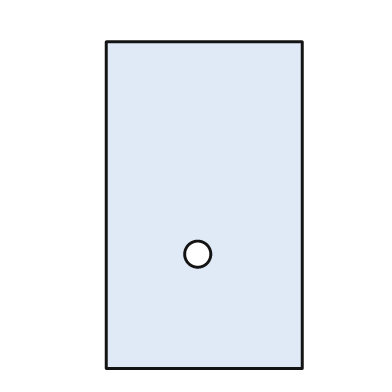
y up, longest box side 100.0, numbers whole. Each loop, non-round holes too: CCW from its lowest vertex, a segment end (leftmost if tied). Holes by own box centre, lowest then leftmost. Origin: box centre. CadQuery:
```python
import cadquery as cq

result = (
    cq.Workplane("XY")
    .moveTo(-30.0, -50.0)
    .lineTo(30.0, -50.0)
    .lineTo(30.0, 50.0)
    .lineTo(-30.0, 50.0)
    .close()
    .moveTo(-2.0, -15.0)
    .circle(4.0)
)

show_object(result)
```